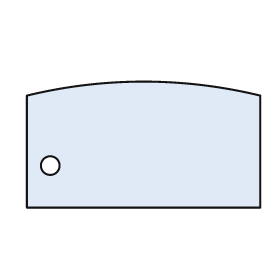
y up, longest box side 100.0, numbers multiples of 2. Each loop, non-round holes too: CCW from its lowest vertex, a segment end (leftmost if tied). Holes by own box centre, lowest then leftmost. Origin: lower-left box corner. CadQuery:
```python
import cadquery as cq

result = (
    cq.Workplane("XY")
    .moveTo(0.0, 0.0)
    .lineTo(100.0, 0.0)
    .lineTo(100.0, 48.0)
    .threePointArc((50.0, 54.0), (0.0, 48.0))
    .close()
    .moveTo(10.0, 18.0)
    .circle(4.0)
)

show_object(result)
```